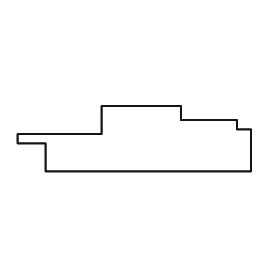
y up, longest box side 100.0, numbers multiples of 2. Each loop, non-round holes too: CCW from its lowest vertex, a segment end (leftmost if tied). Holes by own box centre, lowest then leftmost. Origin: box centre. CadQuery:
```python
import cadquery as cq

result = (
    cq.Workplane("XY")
    .moveTo(-38.0, -14.0)
    .lineTo(50.0, -14.0)
    .lineTo(50.0, 4.0)
    .lineTo(44.0, 4.0)
    .lineTo(44.0, 8.0)
    .lineTo(20.0, 8.0)
    .lineTo(20.0, 14.0)
    .lineTo(-14.0, 14.0)
    .lineTo(-14.0, 2.0)
    .lineTo(-50.0, 2.0)
    .lineTo(-50.0, -2.0)
    .lineTo(-38.0, -2.0)
    .close()
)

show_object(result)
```